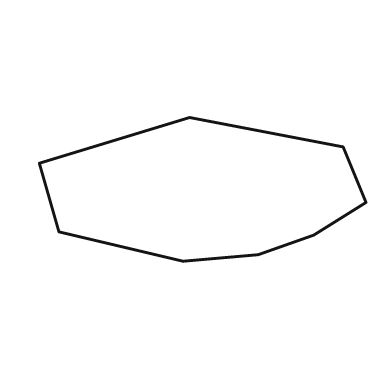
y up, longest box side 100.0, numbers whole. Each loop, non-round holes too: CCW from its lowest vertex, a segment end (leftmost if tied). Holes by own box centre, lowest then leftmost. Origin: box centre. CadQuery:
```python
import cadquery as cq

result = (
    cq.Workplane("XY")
    .moveTo(-6.0, -22.0)
    .lineTo(17.0, -20.0)
    .lineTo(34.0, -14.0)
    .lineTo(50.0, -4.0)
    .lineTo(43.0, 13.0)
    .lineTo(-4.0, 22.0)
    .lineTo(-50.0, 8.0)
    .lineTo(-44.0, -13.0)
    .close()
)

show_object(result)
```